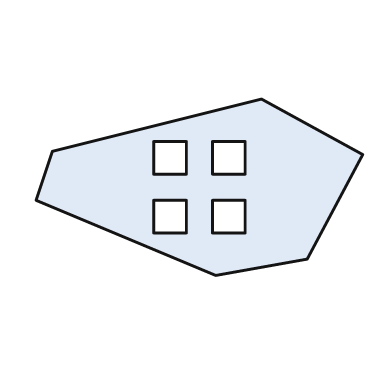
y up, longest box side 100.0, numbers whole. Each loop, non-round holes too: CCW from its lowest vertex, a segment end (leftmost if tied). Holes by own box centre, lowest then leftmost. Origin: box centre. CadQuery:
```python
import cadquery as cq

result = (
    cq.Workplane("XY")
    .moveTo(5.0, -27.0)
    .lineTo(33.0, -22.0)
    .lineTo(50.0, 10.0)
    .lineTo(19.0, 27.0)
    .lineTo(-45.0, 11.0)
    .lineTo(-50.0, -4.0)
    .close()
    .moveTo(-14.0, -14.0)
    .lineTo(-4.0, -14.0)
    .lineTo(-4.0, -4.0)
    .lineTo(-14.0, -4.0)
    .close()
    .moveTo(4.0, -14.0)
    .lineTo(14.0, -14.0)
    .lineTo(14.0, -4.0)
    .lineTo(4.0, -4.0)
    .close()
    .moveTo(-14.0, 4.0)
    .lineTo(-4.0, 4.0)
    .lineTo(-4.0, 14.0)
    .lineTo(-14.0, 14.0)
    .close()
    .moveTo(4.0, 4.0)
    .lineTo(14.0, 4.0)
    .lineTo(14.0, 14.0)
    .lineTo(4.0, 14.0)
    .close()
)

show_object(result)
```